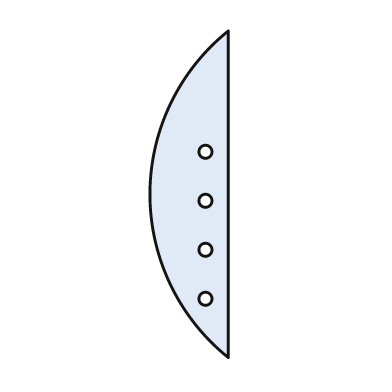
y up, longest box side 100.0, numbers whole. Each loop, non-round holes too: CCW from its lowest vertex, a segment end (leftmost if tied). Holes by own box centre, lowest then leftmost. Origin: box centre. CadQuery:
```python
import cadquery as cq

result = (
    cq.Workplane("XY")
    .moveTo(12.0, -50.0)
    .lineTo(12.0, 50.0)
    .threePointArc((-12.0, 0.0), (12.0, -50.0))
    .close()
    .moveTo(5.0, -32.0)
    .circle(2.0)
    .moveTo(5.0, -17.0)
    .circle(2.0)
    .moveTo(5.0, -2.0)
    .circle(2.0)
    .moveTo(5.0, 13.0)
    .circle(2.0)
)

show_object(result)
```